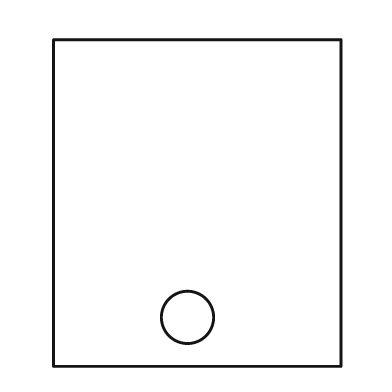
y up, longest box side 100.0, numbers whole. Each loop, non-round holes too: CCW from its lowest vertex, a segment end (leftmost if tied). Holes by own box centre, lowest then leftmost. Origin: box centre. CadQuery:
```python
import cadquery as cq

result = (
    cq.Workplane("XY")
    .moveTo(-44.0, -50.0)
    .lineTo(44.0, -50.0)
    .lineTo(44.0, 50.0)
    .lineTo(-44.0, 50.0)
    .close()
    .moveTo(-3.0, -35.0)
    .circle(8.0)
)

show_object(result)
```